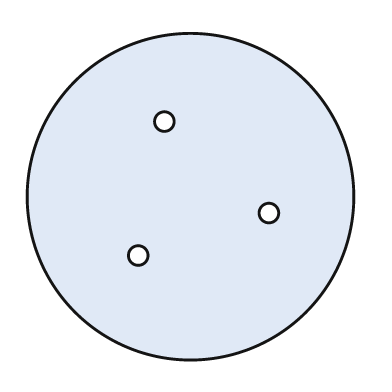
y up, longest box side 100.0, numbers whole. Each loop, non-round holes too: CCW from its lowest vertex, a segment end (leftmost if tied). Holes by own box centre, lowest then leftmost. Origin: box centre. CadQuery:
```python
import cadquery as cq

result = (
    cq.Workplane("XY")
    .moveTo(0.0, 0.0)
    .circle(50.0)
    .moveTo(-16.0, -18.0)
    .circle(3.0)
    .moveTo(24.0, -5.0)
    .circle(3.0)
    .moveTo(-8.0, 23.0)
    .circle(3.0)
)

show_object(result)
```